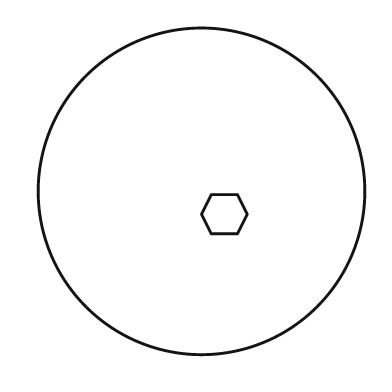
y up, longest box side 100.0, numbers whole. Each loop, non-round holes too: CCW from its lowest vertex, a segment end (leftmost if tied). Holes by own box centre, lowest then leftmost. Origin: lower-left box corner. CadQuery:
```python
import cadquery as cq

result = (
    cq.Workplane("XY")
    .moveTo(50.0, 50.0)
    .circle(50.0)
    .moveTo(53.0, 37.0)
    .lineTo(61.0, 37.0)
    .lineTo(64.0, 43.0)
    .lineTo(61.0, 49.0)
    .lineTo(53.0, 49.0)
    .lineTo(50.0, 43.0)
    .close()
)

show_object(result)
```